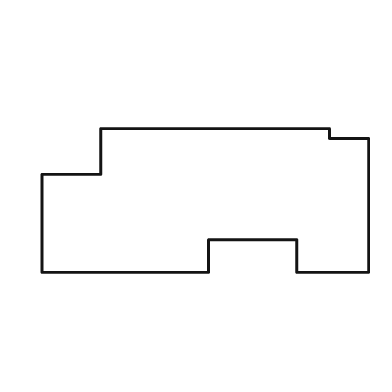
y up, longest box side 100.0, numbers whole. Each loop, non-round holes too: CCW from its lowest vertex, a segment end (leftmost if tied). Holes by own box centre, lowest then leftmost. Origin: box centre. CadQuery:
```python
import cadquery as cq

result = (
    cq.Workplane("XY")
    .moveTo(-50.0, -22.0)
    .lineTo(1.0, -22.0)
    .lineTo(1.0, -12.0)
    .lineTo(28.0, -12.0)
    .lineTo(28.0, -22.0)
    .lineTo(50.0, -22.0)
    .lineTo(50.0, 19.0)
    .lineTo(38.0, 19.0)
    .lineTo(38.0, 22.0)
    .lineTo(-32.0, 22.0)
    .lineTo(-32.0, 8.0)
    .lineTo(-50.0, 8.0)
    .close()
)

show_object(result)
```